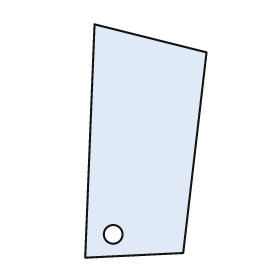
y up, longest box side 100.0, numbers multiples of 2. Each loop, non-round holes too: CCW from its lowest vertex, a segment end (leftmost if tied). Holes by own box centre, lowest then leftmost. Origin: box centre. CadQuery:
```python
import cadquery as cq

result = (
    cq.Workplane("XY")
    .moveTo(-26.0, -50.0)
    .lineTo(16.0, -48.0)
    .lineTo(26.0, 38.0)
    .lineTo(-22.0, 50.0)
    .close()
    .moveTo(-14.0, -40.0)
    .circle(4.0)
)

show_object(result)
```